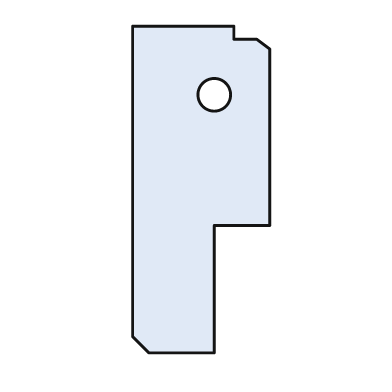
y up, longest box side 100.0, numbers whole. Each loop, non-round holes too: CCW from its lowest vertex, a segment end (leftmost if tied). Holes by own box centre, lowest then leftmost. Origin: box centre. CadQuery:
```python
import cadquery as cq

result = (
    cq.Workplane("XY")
    .moveTo(-16.0, -50.0)
    .lineTo(4.0, -50.0)
    .lineTo(4.0, -11.0)
    .lineTo(21.0, -11.0)
    .lineTo(21.0, 43.0)
    .lineTo(17.0, 46.0)
    .lineTo(10.0, 46.0)
    .lineTo(10.0, 50.0)
    .lineTo(-21.0, 50.0)
    .lineTo(-21.0, -45.0)
    .close()
    .moveTo(4.0, 29.0)
    .circle(5.0)
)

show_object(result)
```